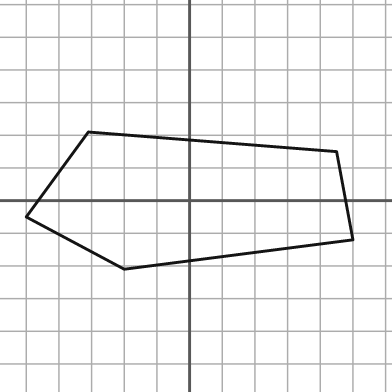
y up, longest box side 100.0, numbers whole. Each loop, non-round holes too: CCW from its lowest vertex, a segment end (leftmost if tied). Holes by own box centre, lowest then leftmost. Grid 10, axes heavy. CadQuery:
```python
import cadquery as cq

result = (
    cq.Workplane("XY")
    .moveTo(-20.0, -21.0)
    .lineTo(50.0, -12.0)
    .lineTo(45.0, 15.0)
    .lineTo(-31.0, 21.0)
    .lineTo(-50.0, -5.0)
    .close()
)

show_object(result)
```